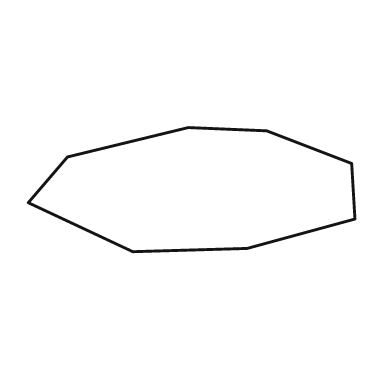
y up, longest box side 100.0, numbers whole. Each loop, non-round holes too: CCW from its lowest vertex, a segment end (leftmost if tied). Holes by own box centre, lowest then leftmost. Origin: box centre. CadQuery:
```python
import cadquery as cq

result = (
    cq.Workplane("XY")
    .moveTo(-18.0, -19.0)
    .lineTo(17.0, -18.0)
    .lineTo(50.0, -9.0)
    .lineTo(49.0, 8.0)
    .lineTo(23.0, 18.0)
    .lineTo(-1.0, 19.0)
    .lineTo(-38.0, 10.0)
    .lineTo(-50.0, -4.0)
    .close()
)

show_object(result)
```